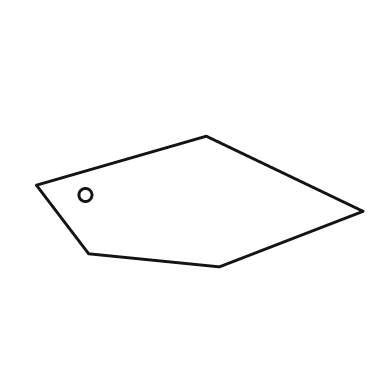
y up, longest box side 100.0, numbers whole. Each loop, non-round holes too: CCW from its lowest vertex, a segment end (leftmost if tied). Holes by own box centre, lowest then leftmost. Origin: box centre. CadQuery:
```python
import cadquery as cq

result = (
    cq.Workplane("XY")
    .moveTo(6.0, -20.0)
    .lineTo(50.0, -3.0)
    .lineTo(2.0, 20.0)
    .lineTo(-50.0, 5.0)
    .lineTo(-34.0, -16.0)
    .close()
    .moveTo(-35.0, 2.0)
    .circle(2.0)
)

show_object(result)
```